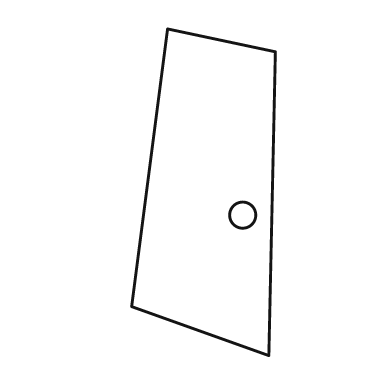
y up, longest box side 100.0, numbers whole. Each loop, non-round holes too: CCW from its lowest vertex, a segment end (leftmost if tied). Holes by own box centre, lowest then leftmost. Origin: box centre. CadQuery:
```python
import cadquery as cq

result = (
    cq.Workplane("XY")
    .moveTo(20.0, -50.0)
    .lineTo(22.0, 43.0)
    .lineTo(-11.0, 50.0)
    .lineTo(-22.0, -35.0)
    .close()
    .moveTo(12.0, -7.0)
    .circle(4.0)
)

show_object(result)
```